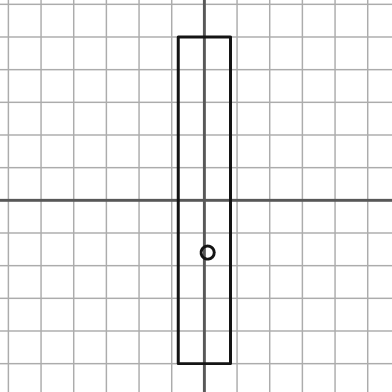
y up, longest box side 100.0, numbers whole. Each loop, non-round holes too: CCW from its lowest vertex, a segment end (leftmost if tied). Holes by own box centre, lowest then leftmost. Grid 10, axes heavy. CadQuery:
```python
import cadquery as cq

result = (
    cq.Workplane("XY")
    .moveTo(-8.0, -50.0)
    .lineTo(8.0, -50.0)
    .lineTo(8.0, 50.0)
    .lineTo(-8.0, 50.0)
    .close()
    .moveTo(1.0, -16.0)
    .circle(2.0)
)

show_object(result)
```